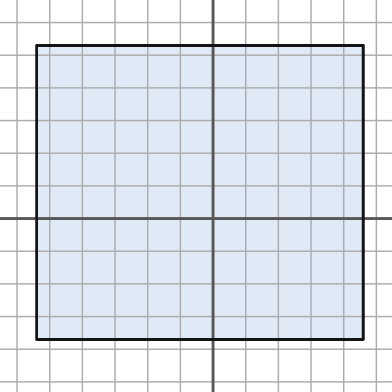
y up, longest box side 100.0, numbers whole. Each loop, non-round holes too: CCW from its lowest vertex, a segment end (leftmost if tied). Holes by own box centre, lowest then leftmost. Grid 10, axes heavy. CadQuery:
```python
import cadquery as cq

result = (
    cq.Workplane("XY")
    .moveTo(-54.0, -37.0)
    .lineTo(46.0, -37.0)
    .lineTo(46.0, 53.0)
    .lineTo(-54.0, 53.0)
    .close()
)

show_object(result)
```